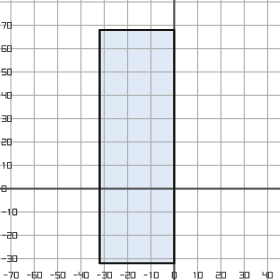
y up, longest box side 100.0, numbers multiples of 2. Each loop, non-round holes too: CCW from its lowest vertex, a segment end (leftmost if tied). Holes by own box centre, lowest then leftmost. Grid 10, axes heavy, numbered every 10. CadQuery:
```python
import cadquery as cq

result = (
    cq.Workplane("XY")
    .moveTo(-32.0, -32.0)
    .lineTo(0.0, -32.0)
    .lineTo(0.0, 68.0)
    .lineTo(-32.0, 68.0)
    .close()
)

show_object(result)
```